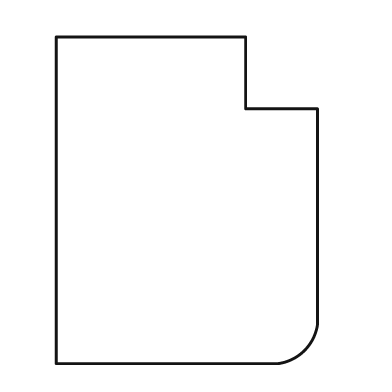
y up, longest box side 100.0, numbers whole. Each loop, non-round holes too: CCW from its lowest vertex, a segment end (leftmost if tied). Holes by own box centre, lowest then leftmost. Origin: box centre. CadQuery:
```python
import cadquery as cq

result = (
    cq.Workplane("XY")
    .moveTo(-40.0, -50.0)
    .lineTo(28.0, -50.0)
    .threePointArc((36.0, -46.0), (40.0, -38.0))
    .lineTo(40.0, 28.0)
    .lineTo(18.0, 28.0)
    .lineTo(18.0, 50.0)
    .lineTo(-40.0, 50.0)
    .close()
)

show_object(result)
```